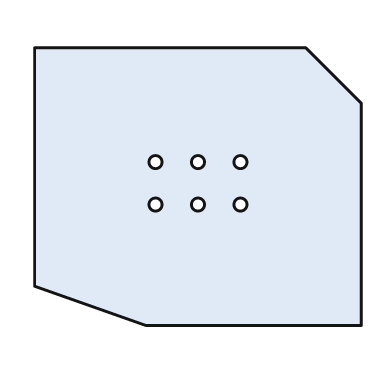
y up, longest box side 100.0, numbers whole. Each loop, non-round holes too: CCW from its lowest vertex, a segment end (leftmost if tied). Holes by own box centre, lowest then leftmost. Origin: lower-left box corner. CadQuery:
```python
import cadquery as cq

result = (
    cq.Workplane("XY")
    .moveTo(34.0, 0.0)
    .lineTo(100.0, 0.0)
    .lineTo(100.0, 68.0)
    .lineTo(83.0, 85.0)
    .lineTo(0.0, 85.0)
    .lineTo(0.0, 12.0)
    .close()
    .moveTo(37.0, 37.0)
    .circle(2.0)
    .moveTo(50.0, 37.0)
    .circle(2.0)
    .moveTo(63.0, 37.0)
    .circle(2.0)
    .moveTo(37.0, 50.0)
    .circle(2.0)
    .moveTo(50.0, 50.0)
    .circle(2.0)
    .moveTo(63.0, 50.0)
    .circle(2.0)
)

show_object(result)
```